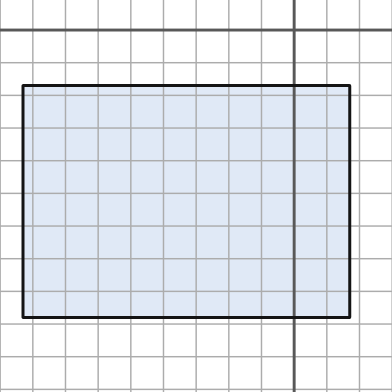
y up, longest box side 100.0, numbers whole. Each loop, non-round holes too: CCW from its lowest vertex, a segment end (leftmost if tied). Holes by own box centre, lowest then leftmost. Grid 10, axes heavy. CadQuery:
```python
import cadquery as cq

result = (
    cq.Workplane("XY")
    .moveTo(-83.0, -88.0)
    .lineTo(17.0, -88.0)
    .lineTo(17.0, -17.0)
    .lineTo(-83.0, -17.0)
    .close()
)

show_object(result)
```